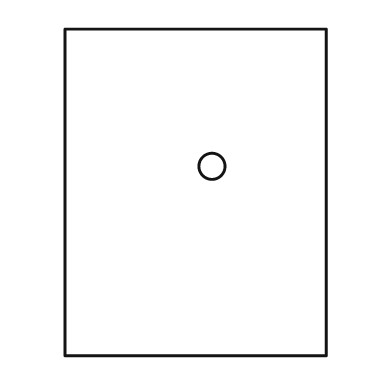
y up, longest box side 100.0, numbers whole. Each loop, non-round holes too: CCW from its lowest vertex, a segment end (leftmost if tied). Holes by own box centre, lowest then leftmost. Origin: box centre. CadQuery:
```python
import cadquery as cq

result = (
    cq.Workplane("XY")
    .moveTo(-40.0, -50.0)
    .lineTo(40.0, -50.0)
    .lineTo(40.0, 50.0)
    .lineTo(-40.0, 50.0)
    .close()
    .moveTo(5.0, 8.0)
    .circle(4.0)
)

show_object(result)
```